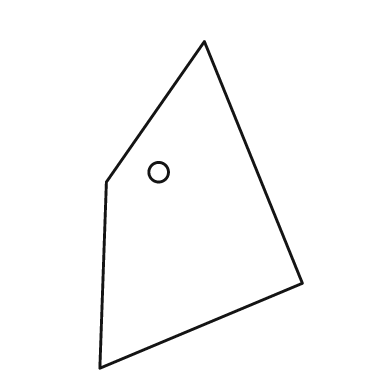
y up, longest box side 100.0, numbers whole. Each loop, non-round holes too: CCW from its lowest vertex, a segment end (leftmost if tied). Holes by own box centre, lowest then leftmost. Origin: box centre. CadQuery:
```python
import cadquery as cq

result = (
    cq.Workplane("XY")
    .moveTo(-31.0, -50.0)
    .lineTo(31.0, -24.0)
    .lineTo(1.0, 50.0)
    .lineTo(-29.0, 7.0)
    .close()
    .moveTo(-13.0, 10.0)
    .circle(3.0)
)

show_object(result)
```